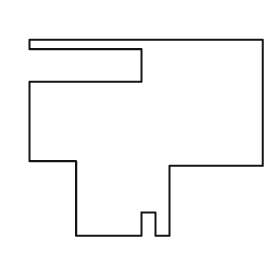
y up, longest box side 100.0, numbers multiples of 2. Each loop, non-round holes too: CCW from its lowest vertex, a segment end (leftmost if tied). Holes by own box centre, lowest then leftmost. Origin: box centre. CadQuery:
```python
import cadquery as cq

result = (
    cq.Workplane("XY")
    .moveTo(-30.0, -42.0)
    .lineTo(-2.0, -42.0)
    .lineTo(-2.0, -32.0)
    .lineTo(4.0, -32.0)
    .lineTo(4.0, -42.0)
    .lineTo(10.0, -42.0)
    .lineTo(10.0, -12.0)
    .lineTo(50.0, -12.0)
    .lineTo(50.0, 42.0)
    .lineTo(-50.0, 42.0)
    .lineTo(-50.0, 38.0)
    .lineTo(-2.0, 38.0)
    .lineTo(-2.0, 24.0)
    .lineTo(-50.0, 24.0)
    .lineTo(-50.0, -10.0)
    .lineTo(-30.0, -10.0)
    .close()
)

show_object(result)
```